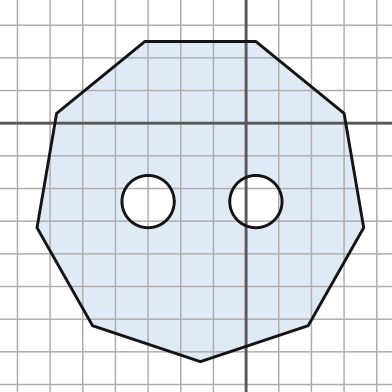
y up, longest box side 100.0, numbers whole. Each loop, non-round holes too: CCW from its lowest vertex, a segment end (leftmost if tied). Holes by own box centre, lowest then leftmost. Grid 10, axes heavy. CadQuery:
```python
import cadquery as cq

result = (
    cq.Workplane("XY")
    .moveTo(-14.0, -73.0)
    .lineTo(19.0, -62.0)
    .lineTo(36.0, -32.0)
    .lineTo(30.0, 3.0)
    .lineTo(3.0, 25.0)
    .lineTo(-31.0, 25.0)
    .lineTo(-58.0, 3.0)
    .lineTo(-64.0, -32.0)
    .lineTo(-47.0, -62.0)
    .close()
    .moveTo(-30.0, -24.0)
    .circle(8.0)
    .moveTo(3.0, -24.0)
    .circle(8.0)
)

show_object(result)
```